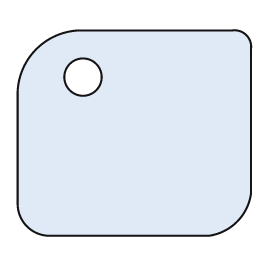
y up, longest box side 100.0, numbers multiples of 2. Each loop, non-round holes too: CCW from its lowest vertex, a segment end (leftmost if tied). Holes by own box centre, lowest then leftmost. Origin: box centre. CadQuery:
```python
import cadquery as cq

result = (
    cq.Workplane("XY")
    .moveTo(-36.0, -44.0)
    .lineTo(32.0, -44.0)
    .threePointArc((44.0, -38.0), (50.0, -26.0))
    .lineTo(50.0, 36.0)
    .threePointArc((48.0, 42.0), (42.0, 44.0))
    .lineTo(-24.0, 44.0)
    .threePointArc((-42.0, 36.0), (-50.0, 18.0))
    .lineTo(-50.0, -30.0)
    .threePointArc((-46.0, -40.0), (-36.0, -44.0))
    .close()
    .moveTo(-22.0, 24.0)
    .circle(8.0)
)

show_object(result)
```